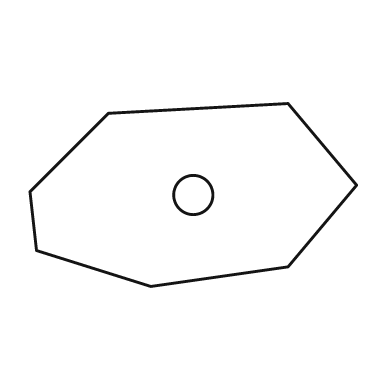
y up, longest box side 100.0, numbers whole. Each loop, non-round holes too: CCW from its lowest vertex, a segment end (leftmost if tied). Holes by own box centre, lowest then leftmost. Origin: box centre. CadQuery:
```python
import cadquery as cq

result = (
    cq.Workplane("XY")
    .moveTo(-13.0, -28.0)
    .lineTo(29.0, -22.0)
    .lineTo(50.0, 3.0)
    .lineTo(29.0, 28.0)
    .lineTo(-26.0, 25.0)
    .lineTo(-50.0, 1.0)
    .lineTo(-48.0, -17.0)
    .close()
    .moveTo(0.0, 0.0)
    .circle(6.0)
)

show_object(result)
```